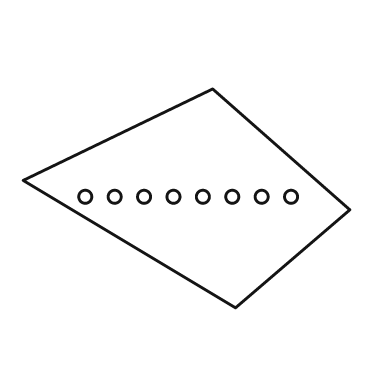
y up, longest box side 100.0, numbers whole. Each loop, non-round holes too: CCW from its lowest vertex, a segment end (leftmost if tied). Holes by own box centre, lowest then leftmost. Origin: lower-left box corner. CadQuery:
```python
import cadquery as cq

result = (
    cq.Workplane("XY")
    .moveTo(65.0, 0.0)
    .lineTo(100.0, 30.0)
    .lineTo(58.0, 67.0)
    .lineTo(0.0, 39.0)
    .close()
    .moveTo(19.0, 34.0)
    .circle(2.0)
    .moveTo(28.0, 34.0)
    .circle(2.0)
    .moveTo(37.0, 34.0)
    .circle(2.0)
    .moveTo(46.0, 34.0)
    .circle(2.0)
    .moveTo(55.0, 34.0)
    .circle(2.0)
    .moveTo(64.0, 34.0)
    .circle(2.0)
    .moveTo(73.0, 34.0)
    .circle(2.0)
    .moveTo(82.0, 34.0)
    .circle(2.0)
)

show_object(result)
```